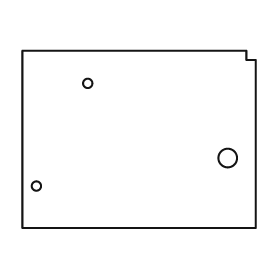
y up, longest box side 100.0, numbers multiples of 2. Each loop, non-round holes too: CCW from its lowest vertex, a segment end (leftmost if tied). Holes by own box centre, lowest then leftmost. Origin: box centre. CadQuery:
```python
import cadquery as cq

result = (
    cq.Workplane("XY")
    .moveTo(-50.0, -38.0)
    .lineTo(50.0, -38.0)
    .lineTo(50.0, 34.0)
    .lineTo(46.0, 34.0)
    .lineTo(46.0, 38.0)
    .lineTo(-50.0, 38.0)
    .close()
    .moveTo(-44.0, -20.0)
    .circle(2.0)
    .moveTo(38.0, -8.0)
    .circle(4.0)
    .moveTo(-22.0, 24.0)
    .circle(2.0)
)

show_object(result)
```